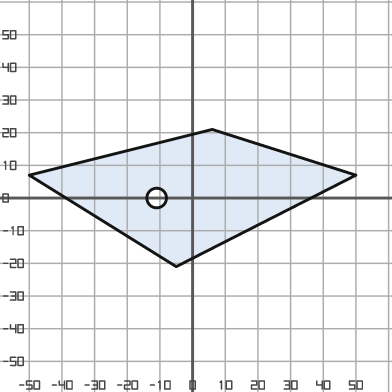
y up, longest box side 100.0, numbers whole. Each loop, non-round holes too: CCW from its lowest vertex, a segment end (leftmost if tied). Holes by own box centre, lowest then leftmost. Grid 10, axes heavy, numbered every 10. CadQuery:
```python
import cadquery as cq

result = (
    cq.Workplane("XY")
    .moveTo(-5.0, -21.0)
    .lineTo(50.0, 7.0)
    .lineTo(6.0, 21.0)
    .lineTo(-50.0, 7.0)
    .close()
    .moveTo(-11.0, 0.0)
    .circle(3.0)
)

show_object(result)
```